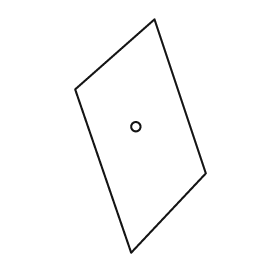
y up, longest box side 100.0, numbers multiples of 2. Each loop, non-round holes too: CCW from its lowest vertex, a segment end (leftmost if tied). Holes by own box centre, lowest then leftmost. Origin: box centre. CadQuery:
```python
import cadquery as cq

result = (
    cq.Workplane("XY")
    .moveTo(-4.0, -50.0)
    .lineTo(28.0, -16.0)
    .lineTo(6.0, 50.0)
    .lineTo(-28.0, 20.0)
    .close()
    .moveTo(-2.0, 4.0)
    .circle(2.0)
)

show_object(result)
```